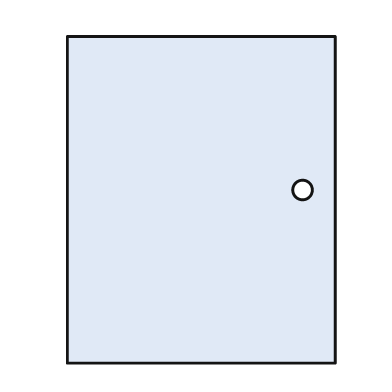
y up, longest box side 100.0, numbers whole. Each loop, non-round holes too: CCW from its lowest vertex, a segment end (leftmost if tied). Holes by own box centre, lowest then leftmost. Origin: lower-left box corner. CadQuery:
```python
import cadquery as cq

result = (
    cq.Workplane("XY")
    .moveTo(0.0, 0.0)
    .lineTo(82.0, 0.0)
    .lineTo(82.0, 100.0)
    .lineTo(0.0, 100.0)
    .close()
    .moveTo(72.0, 53.0)
    .circle(3.0)
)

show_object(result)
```